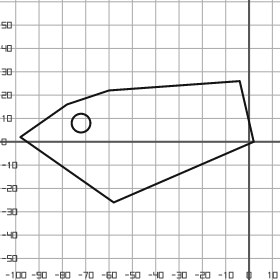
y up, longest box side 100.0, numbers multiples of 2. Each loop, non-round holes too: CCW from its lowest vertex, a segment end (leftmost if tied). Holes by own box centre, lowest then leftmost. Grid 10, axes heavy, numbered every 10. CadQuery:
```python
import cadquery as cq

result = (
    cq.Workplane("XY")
    .moveTo(-58.0, -26.0)
    .lineTo(2.0, 0.0)
    .lineTo(-4.0, 26.0)
    .lineTo(-60.0, 22.0)
    .lineTo(-78.0, 16.0)
    .lineTo(-98.0, 2.0)
    .close()
    .moveTo(-72.0, 8.0)
    .circle(4.0)
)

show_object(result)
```